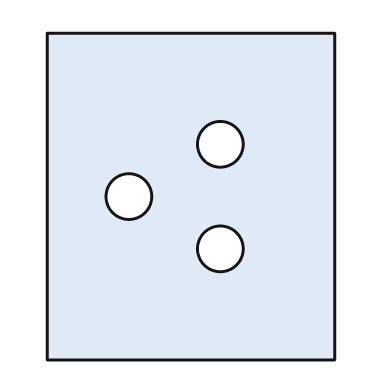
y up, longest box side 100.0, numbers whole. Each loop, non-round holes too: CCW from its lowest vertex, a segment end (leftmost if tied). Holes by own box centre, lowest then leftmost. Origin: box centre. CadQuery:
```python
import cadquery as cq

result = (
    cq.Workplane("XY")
    .moveTo(-44.0, -50.0)
    .lineTo(44.0, -50.0)
    .lineTo(44.0, 50.0)
    .lineTo(-44.0, 50.0)
    .close()
    .moveTo(9.0, -16.0)
    .circle(7.0)
    .moveTo(-19.0, 0.0)
    .circle(7.0)
    .moveTo(9.0, 16.0)
    .circle(7.0)
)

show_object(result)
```